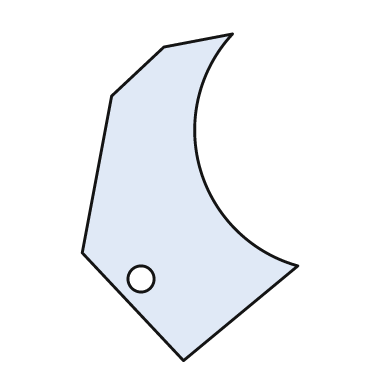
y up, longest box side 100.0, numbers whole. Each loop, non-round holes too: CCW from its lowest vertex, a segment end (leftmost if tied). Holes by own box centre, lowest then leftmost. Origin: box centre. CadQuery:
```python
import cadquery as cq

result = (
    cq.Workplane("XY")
    .moveTo(-2.0, -50.0)
    .lineTo(33.0, -21.0)
    .threePointArc((3.0, 9.0), (13.0, 50.0))
    .lineTo(-8.0, 46.0)
    .lineTo(-24.0, 31.0)
    .lineTo(-33.0, -17.0)
    .close()
    .moveTo(-15.0, -25.0)
    .circle(4.0)
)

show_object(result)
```